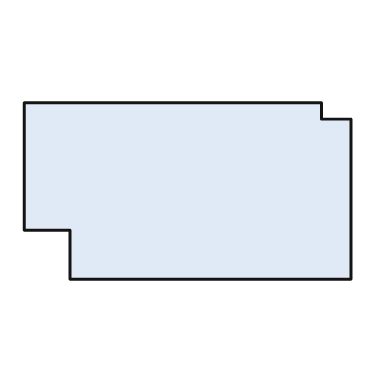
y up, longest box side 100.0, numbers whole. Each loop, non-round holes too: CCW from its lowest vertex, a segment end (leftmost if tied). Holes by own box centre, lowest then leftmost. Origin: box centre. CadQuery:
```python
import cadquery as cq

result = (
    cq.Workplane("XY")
    .moveTo(-36.0, -27.0)
    .lineTo(50.0, -27.0)
    .lineTo(50.0, 22.0)
    .lineTo(41.0, 22.0)
    .lineTo(41.0, 27.0)
    .lineTo(-50.0, 27.0)
    .lineTo(-50.0, -12.0)
    .lineTo(-36.0, -12.0)
    .close()
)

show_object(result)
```